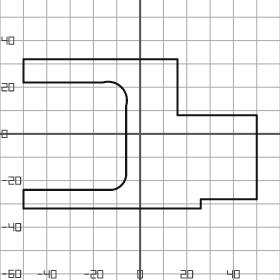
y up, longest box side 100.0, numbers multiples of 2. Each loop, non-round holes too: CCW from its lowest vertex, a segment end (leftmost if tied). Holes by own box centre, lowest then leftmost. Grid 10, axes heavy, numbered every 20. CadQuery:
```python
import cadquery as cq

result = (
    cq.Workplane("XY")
    .moveTo(-50.0, -32.0)
    .lineTo(26.0, -32.0)
    .lineTo(26.0, -28.0)
    .lineTo(50.0, -28.0)
    .lineTo(50.0, 8.0)
    .lineTo(16.0, 8.0)
    .lineTo(16.0, 32.0)
    .lineTo(-50.0, 32.0)
    .lineTo(-50.0, 22.0)
    .lineTo(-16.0, 22.0)
    .threePointArc((-8.0, 20.0), (-6.0, 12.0))
    .lineTo(-6.0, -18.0)
    .threePointArc((-8.0, -22.0), (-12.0, -24.0))
    .lineTo(-50.0, -24.0)
    .close()
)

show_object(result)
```